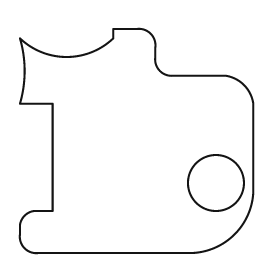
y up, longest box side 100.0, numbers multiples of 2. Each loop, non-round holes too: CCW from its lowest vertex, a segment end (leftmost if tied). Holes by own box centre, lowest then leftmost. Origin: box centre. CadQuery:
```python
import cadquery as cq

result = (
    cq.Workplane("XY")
    .moveTo(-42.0, -48.0)
    .lineTo(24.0, -48.0)
    .threePointArc((42.0, -40.0), (50.0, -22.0))
    .lineTo(50.0, 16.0)
    .threePointArc((46.0, 24.0), (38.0, 28.0))
    .lineTo(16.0, 28.0)
    .threePointArc((10.0, 30.0), (8.0, 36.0))
    .lineTo(8.0, 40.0)
    .threePointArc((6.0, 46.0), (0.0, 48.0))
    .lineTo(-10.0, 48.0)
    .lineTo(-10.0, 44.0)
    .threePointArc((-30.0, 36.0), (-50.0, 44.0))
    .threePointArc((-48.0, 30.0), (-50.0, 16.0))
    .lineTo(-36.0, 16.0)
    .lineTo(-36.0, -30.0)
    .lineTo(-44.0, -30.0)
    .threePointArc((-48.0, -32.0), (-50.0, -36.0))
    .lineTo(-50.0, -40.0)
    .threePointArc((-48.0, -46.0), (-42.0, -48.0))
    .close()
    .moveTo(34.0, -18.0)
    .circle(12.0)
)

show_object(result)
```